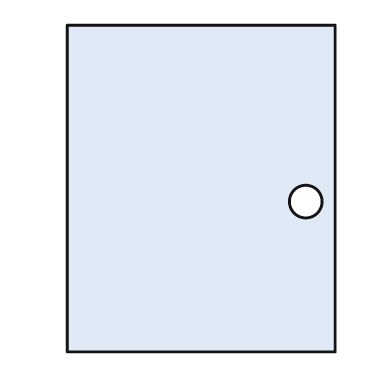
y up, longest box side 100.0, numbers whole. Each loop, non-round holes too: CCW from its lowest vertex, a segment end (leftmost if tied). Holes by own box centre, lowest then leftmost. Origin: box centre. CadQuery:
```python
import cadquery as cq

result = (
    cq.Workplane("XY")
    .moveTo(-41.0, -50.0)
    .lineTo(41.0, -50.0)
    .lineTo(41.0, 50.0)
    .lineTo(-41.0, 50.0)
    .close()
    .moveTo(32.0, -4.0)
    .circle(5.0)
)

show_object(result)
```